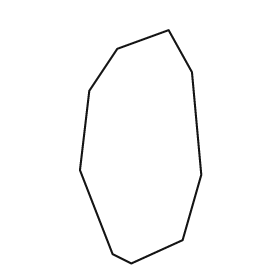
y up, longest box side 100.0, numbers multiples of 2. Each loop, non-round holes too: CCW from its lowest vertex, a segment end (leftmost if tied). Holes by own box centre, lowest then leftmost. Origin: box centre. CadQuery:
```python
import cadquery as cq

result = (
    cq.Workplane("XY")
    .moveTo(-4.0, -50.0)
    .lineTo(18.0, -40.0)
    .lineTo(26.0, -12.0)
    .lineTo(22.0, 32.0)
    .lineTo(12.0, 50.0)
    .lineTo(-10.0, 42.0)
    .lineTo(-22.0, 24.0)
    .lineTo(-26.0, -10.0)
    .lineTo(-12.0, -46.0)
    .close()
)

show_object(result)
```